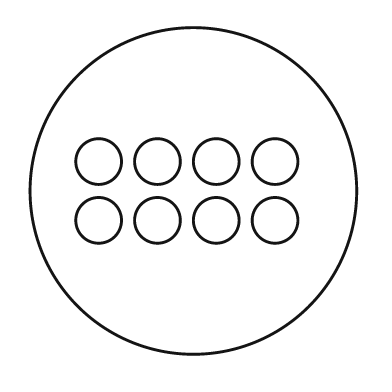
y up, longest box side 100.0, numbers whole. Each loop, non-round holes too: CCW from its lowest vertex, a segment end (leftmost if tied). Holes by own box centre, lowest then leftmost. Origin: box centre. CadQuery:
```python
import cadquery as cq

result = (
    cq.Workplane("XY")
    .moveTo(0.0, 0.0)
    .circle(50.0)
    .moveTo(-29.0, -9.0)
    .circle(7.0)
    .moveTo(-11.0, -9.0)
    .circle(7.0)
    .moveTo(7.0, -9.0)
    .circle(7.0)
    .moveTo(25.0, -9.0)
    .circle(7.0)
    .moveTo(-29.0, 9.0)
    .circle(7.0)
    .moveTo(-11.0, 9.0)
    .circle(7.0)
    .moveTo(7.0, 9.0)
    .circle(7.0)
    .moveTo(25.0, 9.0)
    .circle(7.0)
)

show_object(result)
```